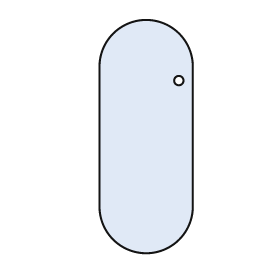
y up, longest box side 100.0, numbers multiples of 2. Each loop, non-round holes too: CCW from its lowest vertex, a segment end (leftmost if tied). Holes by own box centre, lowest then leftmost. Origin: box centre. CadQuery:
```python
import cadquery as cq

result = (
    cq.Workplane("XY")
    .moveTo(-20.0, -30.0)
    .threePointArc((0.0, -50.0), (20.0, -30.0))
    .lineTo(20.0, 30.0)
    .threePointArc((0.0, 50.0), (-20.0, 30.0))
    .close()
    .moveTo(14.0, 24.0)
    .circle(2.0)
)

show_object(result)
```